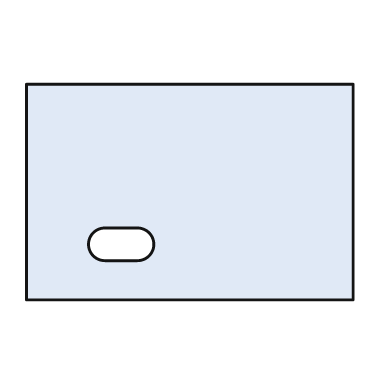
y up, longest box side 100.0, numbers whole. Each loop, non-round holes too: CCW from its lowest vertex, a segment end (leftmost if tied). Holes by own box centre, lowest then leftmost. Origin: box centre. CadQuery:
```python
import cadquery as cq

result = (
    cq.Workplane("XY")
    .moveTo(-50.0, -33.0)
    .lineTo(50.0, -33.0)
    .lineTo(50.0, 33.0)
    .lineTo(-50.0, 33.0)
    .close()
    .moveTo(-26.0, -21.0)
    .lineTo(-16.0, -21.0)
    .threePointArc((-11.0, -16.0), (-16.0, -11.0))
    .lineTo(-26.0, -11.0)
    .threePointArc((-31.0, -16.0), (-26.0, -21.0))
    .close()
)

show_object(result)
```